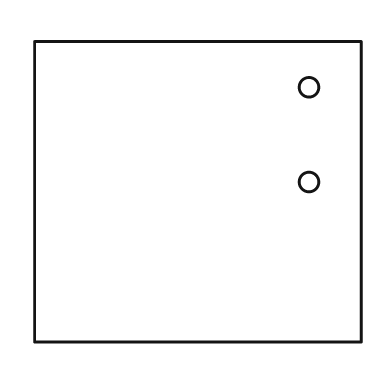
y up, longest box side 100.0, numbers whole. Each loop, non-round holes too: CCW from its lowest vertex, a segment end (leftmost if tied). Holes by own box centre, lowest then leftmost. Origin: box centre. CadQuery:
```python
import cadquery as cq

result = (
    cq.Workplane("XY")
    .moveTo(-50.0, -46.0)
    .lineTo(50.0, -46.0)
    .lineTo(50.0, 46.0)
    .lineTo(-50.0, 46.0)
    .close()
    .moveTo(34.0, 3.0)
    .circle(3.0)
    .moveTo(34.0, 32.0)
    .circle(3.0)
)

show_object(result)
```